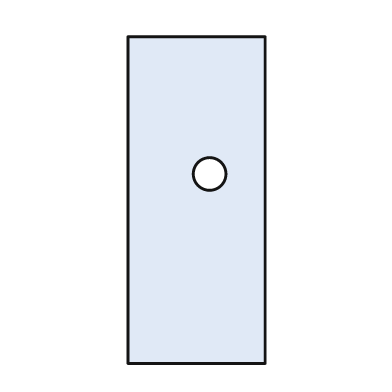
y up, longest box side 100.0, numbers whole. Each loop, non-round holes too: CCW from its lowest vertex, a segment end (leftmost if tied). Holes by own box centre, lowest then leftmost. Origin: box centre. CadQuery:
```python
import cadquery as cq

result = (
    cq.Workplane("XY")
    .moveTo(-21.0, -50.0)
    .lineTo(21.0, -50.0)
    .lineTo(21.0, 50.0)
    .lineTo(-21.0, 50.0)
    .close()
    .moveTo(4.0, 8.0)
    .circle(5.0)
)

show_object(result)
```